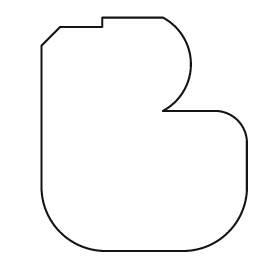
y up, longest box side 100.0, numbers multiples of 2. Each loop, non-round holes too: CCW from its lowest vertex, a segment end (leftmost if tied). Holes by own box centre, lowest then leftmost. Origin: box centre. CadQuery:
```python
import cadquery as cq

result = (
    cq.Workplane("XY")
    .moveTo(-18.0, -50.0)
    .lineTo(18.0, -50.0)
    .threePointArc((36.0, -42.0), (44.0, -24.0))
    .lineTo(44.0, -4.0)
    .threePointArc((40.0, 6.0), (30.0, 10.0))
    .lineTo(8.0, 10.0)
    .threePointArc((20.0, 30.0), (8.0, 50.0))
    .lineTo(-18.0, 50.0)
    .lineTo(-18.0, 46.0)
    .lineTo(-36.0, 46.0)
    .lineTo(-44.0, 38.0)
    .lineTo(-44.0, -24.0)
    .threePointArc((-36.0, -42.0), (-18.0, -50.0))
    .close()
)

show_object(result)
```